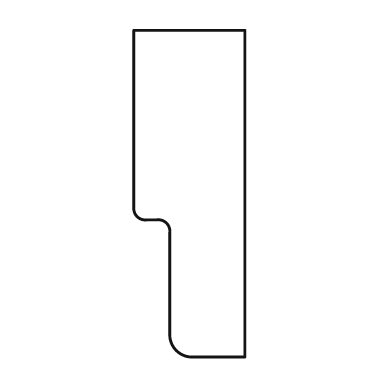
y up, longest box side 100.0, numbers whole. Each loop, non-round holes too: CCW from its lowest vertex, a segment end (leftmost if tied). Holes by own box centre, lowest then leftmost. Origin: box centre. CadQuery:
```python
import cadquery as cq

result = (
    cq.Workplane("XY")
    .moveTo(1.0, -50.0)
    .lineTo(17.0, -50.0)
    .lineTo(17.0, 50.0)
    .lineTo(-17.0, 50.0)
    .lineTo(-17.0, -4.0)
    .threePointArc((-16.0, -7.0), (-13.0, -8.0))
    .lineTo(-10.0, -8.0)
    .threePointArc((-7.0, -9.0), (-6.0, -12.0))
    .lineTo(-6.0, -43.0)
    .threePointArc((-4.0, -48.0), (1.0, -50.0))
    .close()
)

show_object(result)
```